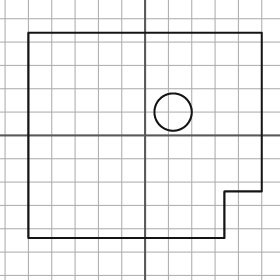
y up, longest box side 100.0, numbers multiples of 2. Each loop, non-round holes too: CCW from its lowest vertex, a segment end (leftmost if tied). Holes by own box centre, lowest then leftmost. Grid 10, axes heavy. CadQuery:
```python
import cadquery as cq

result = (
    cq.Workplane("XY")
    .moveTo(-50.0, -44.0)
    .lineTo(34.0, -44.0)
    .lineTo(34.0, -24.0)
    .lineTo(50.0, -24.0)
    .lineTo(50.0, 44.0)
    .lineTo(-50.0, 44.0)
    .close()
    .moveTo(12.0, 10.0)
    .circle(8.0)
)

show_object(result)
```